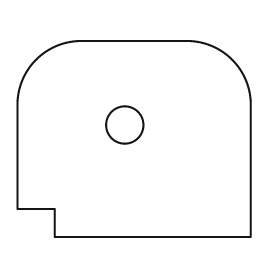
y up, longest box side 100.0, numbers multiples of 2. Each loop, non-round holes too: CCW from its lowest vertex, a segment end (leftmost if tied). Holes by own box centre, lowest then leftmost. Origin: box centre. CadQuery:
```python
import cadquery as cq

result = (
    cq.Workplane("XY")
    .moveTo(-34.0, -42.0)
    .lineTo(50.0, -42.0)
    .lineTo(50.0, 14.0)
    .threePointArc((42.0, 34.0), (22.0, 42.0))
    .lineTo(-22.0, 42.0)
    .threePointArc((-42.0, 34.0), (-50.0, 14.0))
    .lineTo(-50.0, -30.0)
    .lineTo(-34.0, -30.0)
    .close()
    .moveTo(-4.0, 6.0)
    .circle(8.0)
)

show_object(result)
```